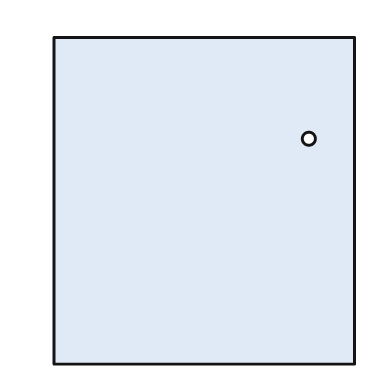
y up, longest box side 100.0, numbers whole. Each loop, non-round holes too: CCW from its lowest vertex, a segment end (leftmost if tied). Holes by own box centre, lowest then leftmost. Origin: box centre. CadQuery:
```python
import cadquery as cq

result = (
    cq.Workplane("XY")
    .moveTo(-46.0, -50.0)
    .lineTo(46.0, -50.0)
    .lineTo(46.0, 50.0)
    .lineTo(-46.0, 50.0)
    .close()
    .moveTo(32.0, 19.0)
    .circle(2.0)
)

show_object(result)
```